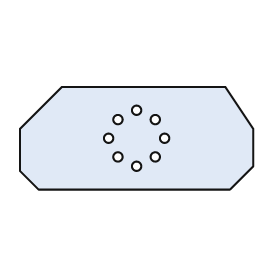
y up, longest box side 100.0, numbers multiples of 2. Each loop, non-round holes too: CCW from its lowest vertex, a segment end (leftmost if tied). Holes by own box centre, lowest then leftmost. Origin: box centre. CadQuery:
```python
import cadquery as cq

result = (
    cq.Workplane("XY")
    .moveTo(-42.0, -22.0)
    .lineTo(40.0, -22.0)
    .lineTo(50.0, -12.0)
    .lineTo(50.0, 4.0)
    .lineTo(38.0, 22.0)
    .lineTo(-32.0, 22.0)
    .lineTo(-50.0, 4.0)
    .lineTo(-50.0, -14.0)
    .close()
    .moveTo(0.0, -12.0)
    .circle(2.0)
    .moveTo(-8.0, -8.0)
    .circle(2.0)
    .moveTo(8.0, -8.0)
    .circle(2.0)
    .moveTo(-12.0, 0.0)
    .circle(2.0)
    .moveTo(12.0, 0.0)
    .circle(2.0)
    .moveTo(-8.0, 8.0)
    .circle(2.0)
    .moveTo(8.0, 8.0)
    .circle(2.0)
    .moveTo(0.0, 12.0)
    .circle(2.0)
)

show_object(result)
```